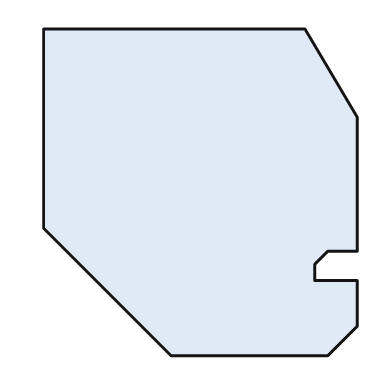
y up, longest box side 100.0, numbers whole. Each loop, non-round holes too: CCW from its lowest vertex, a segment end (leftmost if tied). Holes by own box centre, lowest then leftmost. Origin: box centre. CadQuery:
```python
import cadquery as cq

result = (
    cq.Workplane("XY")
    .moveTo(-9.0, -50.0)
    .lineTo(39.0, -50.0)
    .lineTo(48.0, -41.0)
    .lineTo(48.0, -27.0)
    .lineTo(35.0, -27.0)
    .lineTo(35.0, -22.0)
    .lineTo(39.0, -18.0)
    .lineTo(48.0, -18.0)
    .lineTo(48.0, 23.0)
    .lineTo(32.0, 50.0)
    .lineTo(-48.0, 50.0)
    .lineTo(-48.0, -11.0)
    .close()
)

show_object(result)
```